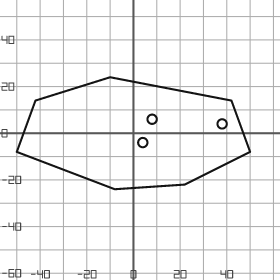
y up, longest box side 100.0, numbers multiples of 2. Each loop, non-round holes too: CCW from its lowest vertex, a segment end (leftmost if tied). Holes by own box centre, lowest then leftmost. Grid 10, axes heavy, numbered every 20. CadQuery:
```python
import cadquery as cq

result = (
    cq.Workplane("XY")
    .moveTo(-8.0, -24.0)
    .lineTo(22.0, -22.0)
    .lineTo(50.0, -8.0)
    .lineTo(42.0, 14.0)
    .lineTo(-10.0, 24.0)
    .lineTo(-42.0, 14.0)
    .lineTo(-50.0, -8.0)
    .close()
    .moveTo(4.0, -4.0)
    .circle(2.0)
    .moveTo(38.0, 4.0)
    .circle(2.0)
    .moveTo(8.0, 6.0)
    .circle(2.0)
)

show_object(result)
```